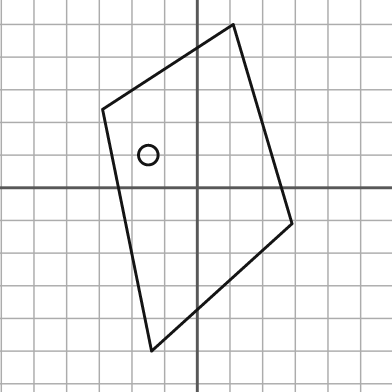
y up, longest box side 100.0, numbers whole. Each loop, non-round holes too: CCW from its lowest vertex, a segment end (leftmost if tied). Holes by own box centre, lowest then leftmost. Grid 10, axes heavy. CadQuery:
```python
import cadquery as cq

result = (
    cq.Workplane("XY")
    .moveTo(-14.0, -50.0)
    .lineTo(29.0, -11.0)
    .lineTo(11.0, 50.0)
    .lineTo(-29.0, 24.0)
    .close()
    .moveTo(-15.0, 10.0)
    .circle(3.0)
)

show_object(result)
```